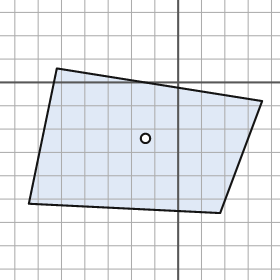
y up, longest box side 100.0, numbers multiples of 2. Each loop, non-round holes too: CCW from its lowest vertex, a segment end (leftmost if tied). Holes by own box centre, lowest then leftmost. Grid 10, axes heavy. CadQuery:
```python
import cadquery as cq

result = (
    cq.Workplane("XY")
    .moveTo(18.0, -56.0)
    .lineTo(36.0, -8.0)
    .lineTo(-52.0, 6.0)
    .lineTo(-64.0, -52.0)
    .close()
    .moveTo(-14.0, -24.0)
    .circle(2.0)
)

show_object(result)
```